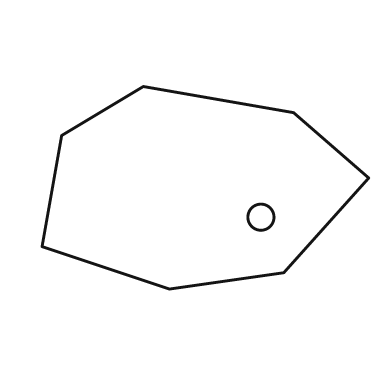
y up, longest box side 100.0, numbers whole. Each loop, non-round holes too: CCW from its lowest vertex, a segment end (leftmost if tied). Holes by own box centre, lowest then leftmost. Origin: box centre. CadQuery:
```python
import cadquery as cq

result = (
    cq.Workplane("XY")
    .moveTo(-11.0, -31.0)
    .lineTo(24.0, -26.0)
    .lineTo(50.0, 3.0)
    .lineTo(27.0, 23.0)
    .lineTo(-19.0, 31.0)
    .lineTo(-44.0, 16.0)
    .lineTo(-50.0, -18.0)
    .close()
    .moveTo(17.0, -9.0)
    .circle(4.0)
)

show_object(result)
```